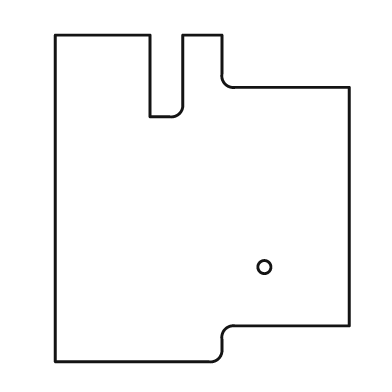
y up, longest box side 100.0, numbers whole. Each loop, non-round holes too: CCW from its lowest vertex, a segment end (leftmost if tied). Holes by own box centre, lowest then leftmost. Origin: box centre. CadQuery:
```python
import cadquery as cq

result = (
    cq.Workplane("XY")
    .moveTo(-45.0, -50.0)
    .lineTo(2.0, -50.0)
    .threePointArc((5.0, -49.0), (6.0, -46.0))
    .lineTo(6.0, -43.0)
    .threePointArc((7.0, -40.0), (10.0, -39.0))
    .lineTo(45.0, -39.0)
    .lineTo(45.0, 34.0)
    .lineTo(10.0, 34.0)
    .threePointArc((7.0, 35.0), (6.0, 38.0))
    .lineTo(6.0, 50.0)
    .lineTo(-6.0, 50.0)
    .lineTo(-6.0, 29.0)
    .threePointArc((-7.0, 26.0), (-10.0, 25.0))
    .lineTo(-16.0, 25.0)
    .lineTo(-16.0, 50.0)
    .lineTo(-45.0, 50.0)
    .close()
    .moveTo(19.0, -21.0)
    .circle(2.0)
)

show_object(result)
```